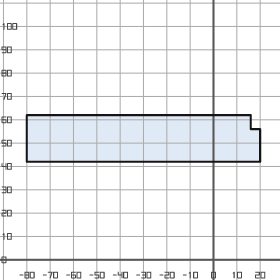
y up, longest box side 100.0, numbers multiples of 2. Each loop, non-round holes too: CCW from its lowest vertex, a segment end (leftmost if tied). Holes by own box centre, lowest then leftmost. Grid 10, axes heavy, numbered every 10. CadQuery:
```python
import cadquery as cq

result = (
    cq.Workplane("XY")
    .moveTo(-80.0, 42.0)
    .lineTo(20.0, 42.0)
    .lineTo(20.0, 56.0)
    .lineTo(16.0, 56.0)
    .lineTo(16.0, 62.0)
    .lineTo(-80.0, 62.0)
    .close()
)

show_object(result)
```